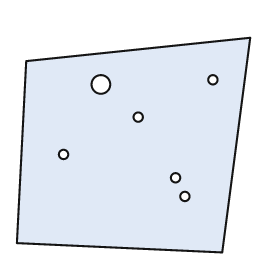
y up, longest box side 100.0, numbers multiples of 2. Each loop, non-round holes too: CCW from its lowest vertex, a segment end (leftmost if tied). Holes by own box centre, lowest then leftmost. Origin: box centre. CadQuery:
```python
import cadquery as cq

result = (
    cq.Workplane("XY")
    .moveTo(38.0, -46.0)
    .lineTo(50.0, 46.0)
    .lineTo(-46.0, 36.0)
    .lineTo(-50.0, -42.0)
    .close()
    .moveTo(22.0, -22.0)
    .circle(2.0)
    .moveTo(18.0, -14.0)
    .circle(2.0)
    .moveTo(-30.0, -4.0)
    .circle(2.0)
    .moveTo(2.0, 12.0)
    .circle(2.0)
    .moveTo(-14.0, 26.0)
    .circle(4.0)
    .moveTo(34.0, 28.0)
    .circle(2.0)
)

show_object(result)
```